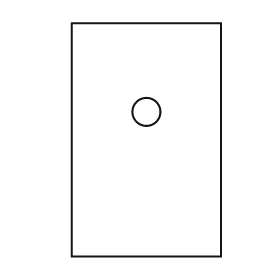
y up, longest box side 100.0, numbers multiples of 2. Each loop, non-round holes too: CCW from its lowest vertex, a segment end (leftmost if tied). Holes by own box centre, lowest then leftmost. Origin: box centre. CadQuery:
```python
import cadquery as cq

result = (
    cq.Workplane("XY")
    .moveTo(-32.0, -50.0)
    .lineTo(32.0, -50.0)
    .lineTo(32.0, 50.0)
    .lineTo(-32.0, 50.0)
    .close()
    .moveTo(0.0, 12.0)
    .circle(6.0)
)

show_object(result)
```